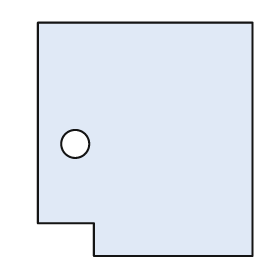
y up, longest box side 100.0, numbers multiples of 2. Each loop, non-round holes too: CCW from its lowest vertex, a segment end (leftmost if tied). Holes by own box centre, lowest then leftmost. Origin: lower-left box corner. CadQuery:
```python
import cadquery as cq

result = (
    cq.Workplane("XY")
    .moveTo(24.0, 0.0)
    .lineTo(92.0, 0.0)
    .lineTo(92.0, 100.0)
    .lineTo(0.0, 100.0)
    .lineTo(0.0, 14.0)
    .lineTo(24.0, 14.0)
    .close()
    .moveTo(16.0, 48.0)
    .circle(6.0)
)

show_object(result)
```